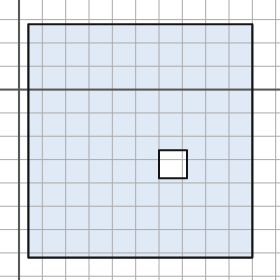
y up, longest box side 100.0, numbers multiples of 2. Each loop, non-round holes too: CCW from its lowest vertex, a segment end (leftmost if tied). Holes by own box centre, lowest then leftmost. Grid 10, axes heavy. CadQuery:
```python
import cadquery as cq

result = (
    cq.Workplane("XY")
    .moveTo(4.0, -72.0)
    .lineTo(100.0, -72.0)
    .lineTo(100.0, 28.0)
    .lineTo(4.0, 28.0)
    .close()
    .moveTo(60.0, -38.0)
    .lineTo(72.0, -38.0)
    .lineTo(72.0, -26.0)
    .lineTo(60.0, -26.0)
    .close()
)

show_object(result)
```